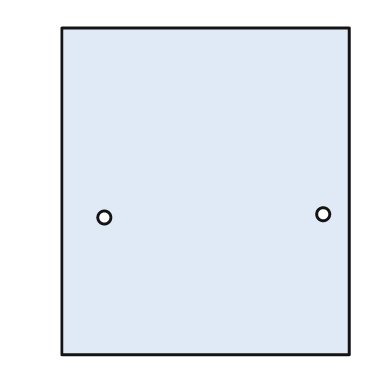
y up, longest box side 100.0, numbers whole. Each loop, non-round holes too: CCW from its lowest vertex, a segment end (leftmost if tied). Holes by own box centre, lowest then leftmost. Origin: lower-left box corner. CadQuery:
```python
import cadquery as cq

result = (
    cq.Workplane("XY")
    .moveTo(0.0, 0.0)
    .lineTo(88.0, 0.0)
    .lineTo(88.0, 100.0)
    .lineTo(0.0, 100.0)
    .close()
    .moveTo(13.0, 42.0)
    .circle(2.0)
    .moveTo(80.0, 43.0)
    .circle(2.0)
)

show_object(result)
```